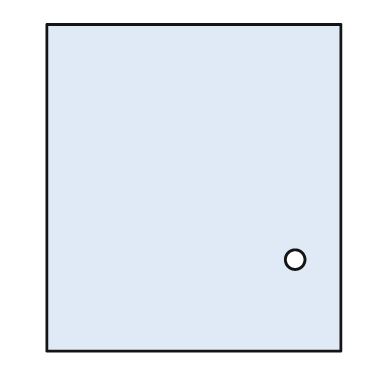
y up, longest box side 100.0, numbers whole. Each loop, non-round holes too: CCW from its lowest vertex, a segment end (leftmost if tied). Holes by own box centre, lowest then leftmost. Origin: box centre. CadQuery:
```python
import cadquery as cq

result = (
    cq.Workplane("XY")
    .moveTo(-45.0, -50.0)
    .lineTo(45.0, -50.0)
    .lineTo(45.0, 50.0)
    .lineTo(-45.0, 50.0)
    .close()
    .moveTo(31.0, -22.0)
    .circle(3.0)
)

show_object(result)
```